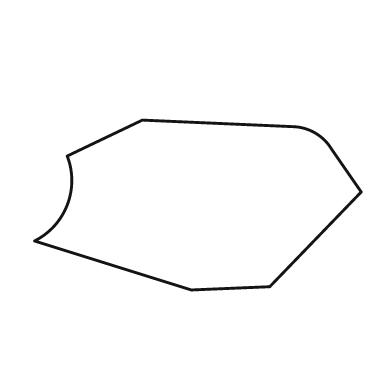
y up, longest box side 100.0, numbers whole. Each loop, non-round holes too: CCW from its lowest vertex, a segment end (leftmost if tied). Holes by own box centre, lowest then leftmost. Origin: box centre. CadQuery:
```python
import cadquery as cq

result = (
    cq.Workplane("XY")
    .moveTo(-2.0, -26.0)
    .lineTo(22.0, -25.0)
    .lineTo(50.0, 4.0)
    .lineTo(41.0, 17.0)
    .threePointArc((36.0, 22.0), (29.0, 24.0))
    .lineTo(-17.0, 26.0)
    .lineTo(-40.0, 15.0)
    .threePointArc((-40.0, 0.0), (-50.0, -11.0))
    .close()
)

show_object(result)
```